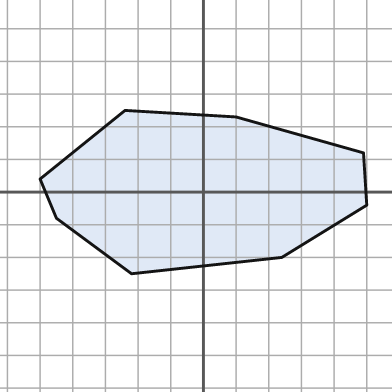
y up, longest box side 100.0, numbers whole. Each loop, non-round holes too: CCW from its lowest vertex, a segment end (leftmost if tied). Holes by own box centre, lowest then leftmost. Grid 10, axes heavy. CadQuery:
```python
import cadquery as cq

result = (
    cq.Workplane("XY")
    .moveTo(-22.0, -25.0)
    .lineTo(24.0, -20.0)
    .lineTo(50.0, -4.0)
    .lineTo(49.0, 12.0)
    .lineTo(10.0, 23.0)
    .lineTo(-24.0, 25.0)
    .lineTo(-50.0, 4.0)
    .lineTo(-45.0, -8.0)
    .close()
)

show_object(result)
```